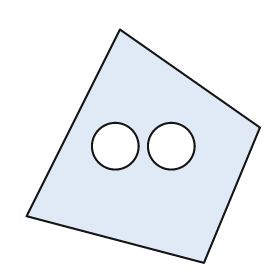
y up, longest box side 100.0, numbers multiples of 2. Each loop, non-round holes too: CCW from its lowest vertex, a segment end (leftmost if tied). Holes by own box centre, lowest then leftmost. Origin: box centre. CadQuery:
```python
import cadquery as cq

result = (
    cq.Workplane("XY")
    .moveTo(26.0, -50.0)
    .lineTo(50.0, 8.0)
    .lineTo(-10.0, 50.0)
    .lineTo(-50.0, -30.0)
    .close()
    .moveTo(-12.0, 0.0)
    .circle(10.0)
    .moveTo(12.0, 0.0)
    .circle(10.0)
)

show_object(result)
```